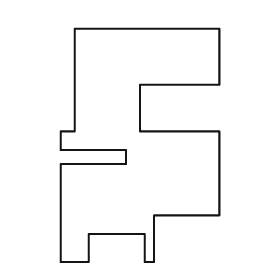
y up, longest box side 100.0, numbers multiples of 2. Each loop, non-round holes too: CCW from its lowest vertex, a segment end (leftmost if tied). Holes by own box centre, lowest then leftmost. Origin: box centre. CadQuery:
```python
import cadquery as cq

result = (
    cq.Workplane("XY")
    .moveTo(-34.0, -50.0)
    .lineTo(-22.0, -50.0)
    .lineTo(-22.0, -38.0)
    .lineTo(2.0, -38.0)
    .lineTo(2.0, -50.0)
    .lineTo(6.0, -50.0)
    .lineTo(6.0, -30.0)
    .lineTo(34.0, -30.0)
    .lineTo(34.0, 6.0)
    .lineTo(0.0, 6.0)
    .lineTo(0.0, 26.0)
    .lineTo(34.0, 26.0)
    .lineTo(34.0, 50.0)
    .lineTo(-28.0, 50.0)
    .lineTo(-28.0, 6.0)
    .lineTo(-34.0, 6.0)
    .lineTo(-34.0, -2.0)
    .lineTo(-6.0, -2.0)
    .lineTo(-6.0, -8.0)
    .lineTo(-34.0, -8.0)
    .close()
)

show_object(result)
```